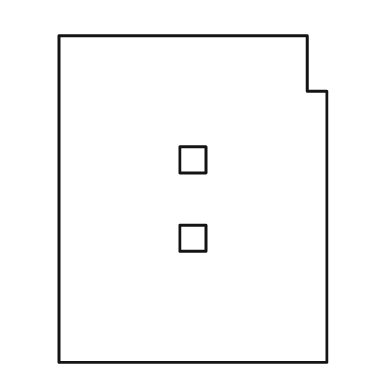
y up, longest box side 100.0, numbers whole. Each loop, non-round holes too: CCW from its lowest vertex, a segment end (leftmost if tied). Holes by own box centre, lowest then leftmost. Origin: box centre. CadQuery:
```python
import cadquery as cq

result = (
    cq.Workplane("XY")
    .moveTo(-41.0, -50.0)
    .lineTo(41.0, -50.0)
    .lineTo(41.0, 33.0)
    .lineTo(35.0, 33.0)
    .lineTo(35.0, 50.0)
    .lineTo(-41.0, 50.0)
    .close()
    .moveTo(-4.0, -16.0)
    .lineTo(4.0, -16.0)
    .lineTo(4.0, -8.0)
    .lineTo(-4.0, -8.0)
    .close()
    .moveTo(-4.0, 8.0)
    .lineTo(4.0, 8.0)
    .lineTo(4.0, 16.0)
    .lineTo(-4.0, 16.0)
    .close()
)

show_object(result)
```